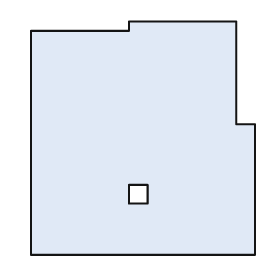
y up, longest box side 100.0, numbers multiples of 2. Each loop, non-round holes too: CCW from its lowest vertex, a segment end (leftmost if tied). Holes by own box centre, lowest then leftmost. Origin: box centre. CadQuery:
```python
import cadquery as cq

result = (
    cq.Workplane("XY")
    .moveTo(-48.0, -50.0)
    .lineTo(48.0, -50.0)
    .lineTo(48.0, 6.0)
    .lineTo(40.0, 6.0)
    .lineTo(40.0, 50.0)
    .lineTo(-6.0, 50.0)
    .lineTo(-6.0, 46.0)
    .lineTo(-48.0, 46.0)
    .close()
    .moveTo(-6.0, -28.0)
    .lineTo(2.0, -28.0)
    .lineTo(2.0, -20.0)
    .lineTo(-6.0, -20.0)
    .close()
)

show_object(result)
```